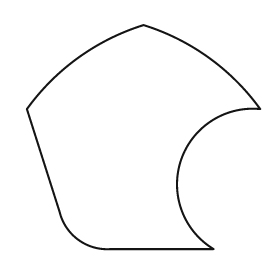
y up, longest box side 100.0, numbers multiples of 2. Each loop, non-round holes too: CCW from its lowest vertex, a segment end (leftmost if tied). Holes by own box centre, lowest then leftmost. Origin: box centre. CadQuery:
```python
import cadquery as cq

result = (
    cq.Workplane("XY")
    .moveTo(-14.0, -48.0)
    .lineTo(30.0, -48.0)
    .threePointArc((16.0, -10.0), (50.0, 12.0))
    .threePointArc((28.0, 34.0), (0.0, 48.0))
    .threePointArc((-28.0, 34.0), (-50.0, 12.0))
    .lineTo(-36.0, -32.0)
    .threePointArc((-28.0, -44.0), (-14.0, -48.0))
    .close()
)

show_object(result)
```